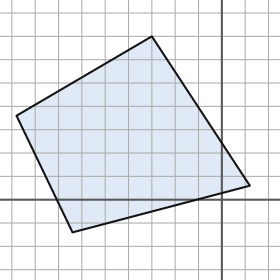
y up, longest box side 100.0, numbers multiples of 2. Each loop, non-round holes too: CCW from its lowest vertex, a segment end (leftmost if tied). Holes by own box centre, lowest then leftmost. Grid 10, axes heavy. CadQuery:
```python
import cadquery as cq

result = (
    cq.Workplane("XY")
    .moveTo(-64.0, -14.0)
    .lineTo(12.0, 6.0)
    .lineTo(-30.0, 70.0)
    .lineTo(-88.0, 36.0)
    .close()
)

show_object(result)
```